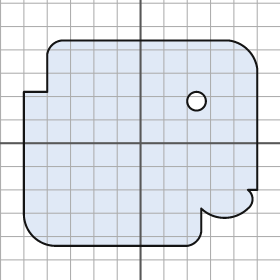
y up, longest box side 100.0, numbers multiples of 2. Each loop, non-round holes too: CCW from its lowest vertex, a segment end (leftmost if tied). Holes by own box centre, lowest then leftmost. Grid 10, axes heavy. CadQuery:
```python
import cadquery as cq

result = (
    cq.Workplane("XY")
    .moveTo(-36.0, -44.0)
    .lineTo(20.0, -44.0)
    .threePointArc((24.0, -42.0), (26.0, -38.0))
    .lineTo(26.0, -28.0)
    .threePointArc((36.0, -32.0), (46.0, -28.0))
    .threePointArc((48.0, -24.0), (46.0, -20.0))
    .lineTo(50.0, -20.0)
    .lineTo(50.0, 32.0)
    .threePointArc((46.0, 40.0), (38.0, 44.0))
    .lineTo(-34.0, 44.0)
    .threePointArc((-38.0, 42.0), (-40.0, 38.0))
    .lineTo(-40.0, 22.0)
    .lineTo(-50.0, 22.0)
    .lineTo(-50.0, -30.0)
    .threePointArc((-46.0, -40.0), (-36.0, -44.0))
    .close()
    .moveTo(24.0, 18.0)
    .circle(4.0)
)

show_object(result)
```